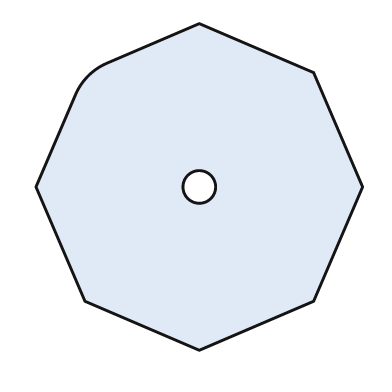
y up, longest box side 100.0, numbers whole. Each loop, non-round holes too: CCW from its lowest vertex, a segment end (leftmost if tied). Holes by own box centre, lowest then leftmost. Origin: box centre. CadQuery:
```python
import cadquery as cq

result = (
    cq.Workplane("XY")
    .moveTo(0.0, -50.0)
    .lineTo(35.0, -35.0)
    .lineTo(50.0, 0.0)
    .lineTo(35.0, 35.0)
    .lineTo(0.0, 50.0)
    .lineTo(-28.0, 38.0)
    .threePointArc((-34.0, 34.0), (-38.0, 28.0))
    .lineTo(-50.0, 0.0)
    .lineTo(-35.0, -35.0)
    .close()
    .moveTo(0.0, 0.0)
    .circle(5.0)
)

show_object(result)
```